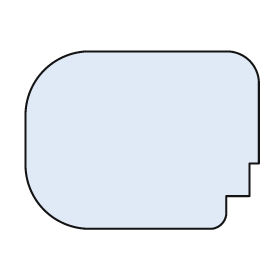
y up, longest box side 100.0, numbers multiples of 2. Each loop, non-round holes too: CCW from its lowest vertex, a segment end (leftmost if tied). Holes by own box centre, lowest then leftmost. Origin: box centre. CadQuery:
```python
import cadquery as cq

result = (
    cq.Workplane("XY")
    .moveTo(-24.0, -38.0)
    .lineTo(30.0, -38.0)
    .threePointArc((34.0, -36.0), (36.0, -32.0))
    .lineTo(36.0, -24.0)
    .lineTo(46.0, -24.0)
    .lineTo(46.0, -10.0)
    .lineTo(50.0, -10.0)
    .lineTo(50.0, 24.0)
    .threePointArc((46.0, 34.0), (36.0, 38.0))
    .lineTo(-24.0, 38.0)
    .threePointArc((-42.0, 30.0), (-50.0, 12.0))
    .lineTo(-50.0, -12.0)
    .threePointArc((-42.0, -30.0), (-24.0, -38.0))
    .close()
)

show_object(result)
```